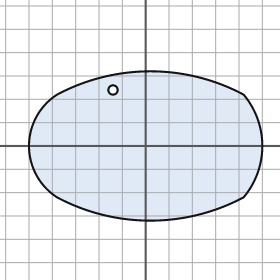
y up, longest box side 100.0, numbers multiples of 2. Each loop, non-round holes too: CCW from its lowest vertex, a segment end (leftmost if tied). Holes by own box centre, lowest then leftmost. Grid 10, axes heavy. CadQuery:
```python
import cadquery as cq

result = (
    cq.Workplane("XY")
    .moveTo(-38.0, -22.0)
    .threePointArc((2.0, -32.0), (42.0, -22.0))
    .threePointArc((50.0, 0.0), (42.0, 22.0))
    .threePointArc((2.0, 32.0), (-38.0, 22.0))
    .threePointArc((-50.0, 0.0), (-38.0, -22.0))
    .close()
    .moveTo(-14.0, 24.0)
    .circle(2.0)
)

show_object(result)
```